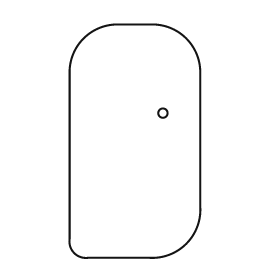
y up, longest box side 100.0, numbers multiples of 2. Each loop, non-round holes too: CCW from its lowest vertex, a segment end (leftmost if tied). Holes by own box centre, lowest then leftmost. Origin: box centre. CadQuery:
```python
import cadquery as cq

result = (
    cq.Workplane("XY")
    .moveTo(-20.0, -50.0)
    .lineTo(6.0, -50.0)
    .threePointArc((22.0, -44.0), (28.0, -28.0))
    .lineTo(28.0, 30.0)
    .threePointArc((22.0, 44.0), (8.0, 50.0))
    .lineTo(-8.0, 50.0)
    .threePointArc((-22.0, 44.0), (-28.0, 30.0))
    .lineTo(-28.0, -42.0)
    .threePointArc((-26.0, -48.0), (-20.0, -50.0))
    .close()
    .moveTo(12.0, 12.0)
    .circle(2.0)
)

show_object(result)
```